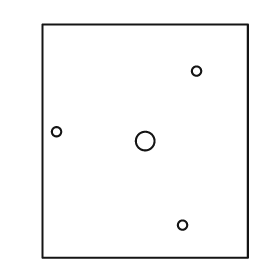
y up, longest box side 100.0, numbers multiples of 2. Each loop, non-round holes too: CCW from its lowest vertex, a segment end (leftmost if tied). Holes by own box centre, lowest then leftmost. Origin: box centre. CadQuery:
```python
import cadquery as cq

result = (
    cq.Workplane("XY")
    .moveTo(-44.0, -50.0)
    .lineTo(44.0, -50.0)
    .lineTo(44.0, 50.0)
    .lineTo(-44.0, 50.0)
    .close()
    .moveTo(16.0, -36.0)
    .circle(2.0)
    .moveTo(0.0, 0.0)
    .circle(4.0)
    .moveTo(-38.0, 4.0)
    .circle(2.0)
    .moveTo(22.0, 30.0)
    .circle(2.0)
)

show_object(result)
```